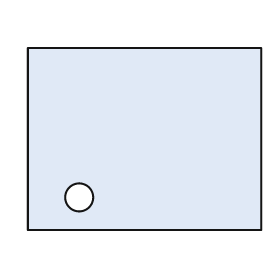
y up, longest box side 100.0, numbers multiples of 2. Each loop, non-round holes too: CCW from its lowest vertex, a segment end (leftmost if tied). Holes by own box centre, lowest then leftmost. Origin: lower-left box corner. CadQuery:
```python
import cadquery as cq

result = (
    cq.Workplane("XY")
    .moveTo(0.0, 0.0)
    .lineTo(100.0, 0.0)
    .lineTo(100.0, 78.0)
    .lineTo(0.0, 78.0)
    .close()
    .moveTo(22.0, 14.0)
    .circle(6.0)
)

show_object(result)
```